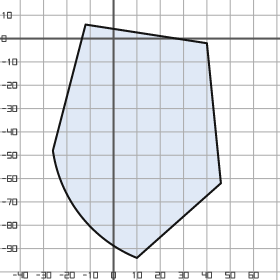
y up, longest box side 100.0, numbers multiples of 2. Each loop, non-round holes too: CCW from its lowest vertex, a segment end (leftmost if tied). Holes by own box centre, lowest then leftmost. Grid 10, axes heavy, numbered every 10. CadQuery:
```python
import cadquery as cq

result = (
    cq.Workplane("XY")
    .moveTo(10.0, -94.0)
    .lineTo(46.0, -62.0)
    .lineTo(40.0, -2.0)
    .lineTo(-12.0, 6.0)
    .lineTo(-26.0, -48.0)
    .threePointArc((-14.0, -76.0), (10.0, -94.0))
    .close()
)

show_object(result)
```